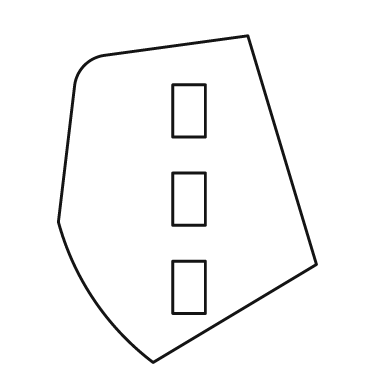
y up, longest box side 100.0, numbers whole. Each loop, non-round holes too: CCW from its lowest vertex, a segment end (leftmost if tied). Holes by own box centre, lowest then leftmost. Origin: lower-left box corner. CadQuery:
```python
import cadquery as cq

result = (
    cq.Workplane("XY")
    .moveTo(29.0, 0.0)
    .lineTo(79.0, 30.0)
    .lineTo(58.0, 100.0)
    .lineTo(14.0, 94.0)
    .threePointArc((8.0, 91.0), (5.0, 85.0))
    .lineTo(0.0, 43.0)
    .threePointArc((11.0, 19.0), (29.0, 0.0))
    .close()
    .moveTo(35.0, 15.0)
    .lineTo(45.0, 15.0)
    .lineTo(45.0, 31.0)
    .lineTo(35.0, 31.0)
    .close()
    .moveTo(35.0, 42.0)
    .lineTo(45.0, 42.0)
    .lineTo(45.0, 58.0)
    .lineTo(35.0, 58.0)
    .close()
    .moveTo(35.0, 69.0)
    .lineTo(45.0, 69.0)
    .lineTo(45.0, 85.0)
    .lineTo(35.0, 85.0)
    .close()
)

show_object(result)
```